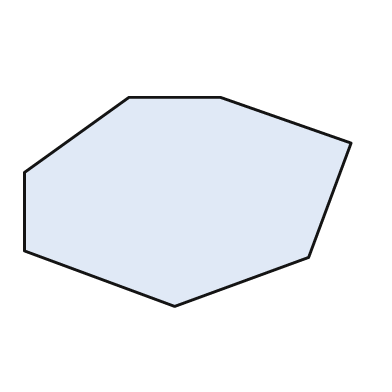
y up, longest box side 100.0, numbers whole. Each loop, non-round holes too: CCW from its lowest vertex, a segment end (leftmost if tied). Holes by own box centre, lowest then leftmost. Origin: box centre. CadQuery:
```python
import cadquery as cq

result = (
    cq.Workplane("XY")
    .moveTo(-4.0, -32.0)
    .lineTo(37.0, -17.0)
    .lineTo(50.0, 18.0)
    .lineTo(10.0, 32.0)
    .lineTo(-18.0, 32.0)
    .lineTo(-50.0, 9.0)
    .lineTo(-50.0, -15.0)
    .close()
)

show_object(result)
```